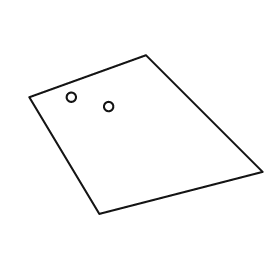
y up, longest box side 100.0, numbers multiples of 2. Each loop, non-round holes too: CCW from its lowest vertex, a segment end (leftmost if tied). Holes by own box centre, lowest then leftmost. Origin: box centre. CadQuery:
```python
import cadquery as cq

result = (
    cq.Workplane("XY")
    .moveTo(-20.0, -34.0)
    .lineTo(50.0, -16.0)
    .lineTo(0.0, 34.0)
    .lineTo(-50.0, 16.0)
    .close()
    .moveTo(-16.0, 12.0)
    .circle(2.0)
    .moveTo(-32.0, 16.0)
    .circle(2.0)
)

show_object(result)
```